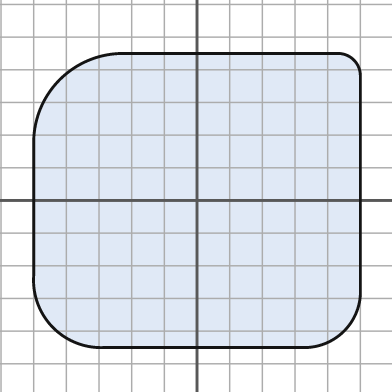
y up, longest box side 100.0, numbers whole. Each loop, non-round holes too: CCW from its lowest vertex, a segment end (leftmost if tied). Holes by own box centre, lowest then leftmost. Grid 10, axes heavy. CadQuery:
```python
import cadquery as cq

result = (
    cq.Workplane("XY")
    .moveTo(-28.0, -45.0)
    .lineTo(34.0, -45.0)
    .threePointArc((45.0, -40.0), (50.0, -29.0))
    .lineTo(50.0, 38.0)
    .threePointArc((48.0, 43.0), (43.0, 45.0))
    .lineTo(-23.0, 45.0)
    .threePointArc((-42.0, 37.0), (-50.0, 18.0))
    .lineTo(-50.0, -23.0)
    .threePointArc((-44.0, -39.0), (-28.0, -45.0))
    .close()
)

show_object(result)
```